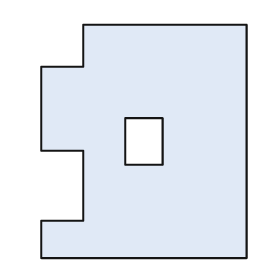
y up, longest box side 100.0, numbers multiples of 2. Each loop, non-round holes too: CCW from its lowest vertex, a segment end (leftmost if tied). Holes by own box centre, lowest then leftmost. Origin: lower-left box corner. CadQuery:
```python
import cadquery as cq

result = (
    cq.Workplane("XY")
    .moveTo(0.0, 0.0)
    .lineTo(88.0, 0.0)
    .lineTo(88.0, 100.0)
    .lineTo(18.0, 100.0)
    .lineTo(18.0, 82.0)
    .lineTo(0.0, 82.0)
    .lineTo(0.0, 46.0)
    .lineTo(18.0, 46.0)
    .lineTo(18.0, 16.0)
    .lineTo(0.0, 16.0)
    .close()
    .moveTo(36.0, 40.0)
    .lineTo(52.0, 40.0)
    .lineTo(52.0, 60.0)
    .lineTo(36.0, 60.0)
    .close()
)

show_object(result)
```